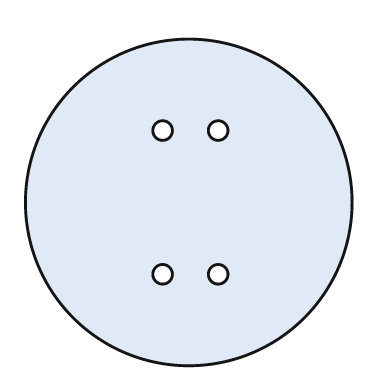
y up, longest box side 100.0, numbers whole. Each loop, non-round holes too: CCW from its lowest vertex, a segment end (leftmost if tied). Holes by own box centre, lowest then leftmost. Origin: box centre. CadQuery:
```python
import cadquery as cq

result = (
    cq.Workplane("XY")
    .moveTo(0.0, 0.0)
    .circle(50.0)
    .moveTo(-8.0, -22.0)
    .circle(3.0)
    .moveTo(9.0, -22.0)
    .circle(3.0)
    .moveTo(-8.0, 22.0)
    .circle(3.0)
    .moveTo(9.0, 22.0)
    .circle(3.0)
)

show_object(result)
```